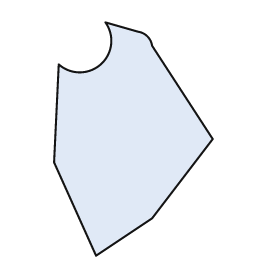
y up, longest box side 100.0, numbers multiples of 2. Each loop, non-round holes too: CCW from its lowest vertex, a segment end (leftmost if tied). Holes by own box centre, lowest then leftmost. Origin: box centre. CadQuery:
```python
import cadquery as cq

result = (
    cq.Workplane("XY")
    .moveTo(-16.0, -50.0)
    .lineTo(8.0, -34.0)
    .lineTo(34.0, 0.0)
    .lineTo(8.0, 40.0)
    .threePointArc((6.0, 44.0), (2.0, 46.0))
    .lineTo(-12.0, 50.0)
    .threePointArc((-14.0, 32.0), (-32.0, 32.0))
    .lineTo(-34.0, -10.0)
    .close()
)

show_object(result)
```